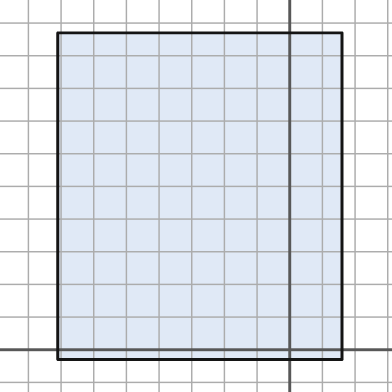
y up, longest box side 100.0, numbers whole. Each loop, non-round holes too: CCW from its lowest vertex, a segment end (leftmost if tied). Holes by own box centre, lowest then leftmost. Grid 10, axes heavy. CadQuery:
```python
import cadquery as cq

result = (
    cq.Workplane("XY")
    .moveTo(-71.0, -3.0)
    .lineTo(16.0, -3.0)
    .lineTo(16.0, 97.0)
    .lineTo(-71.0, 97.0)
    .close()
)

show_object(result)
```